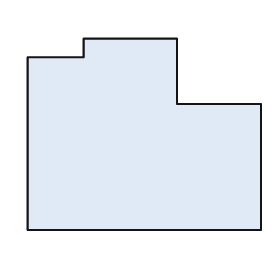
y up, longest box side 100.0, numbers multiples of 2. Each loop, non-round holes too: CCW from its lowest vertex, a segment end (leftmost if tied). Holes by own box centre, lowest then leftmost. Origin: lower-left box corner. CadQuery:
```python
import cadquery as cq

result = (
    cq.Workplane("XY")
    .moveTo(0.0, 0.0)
    .lineTo(100.0, 0.0)
    .lineTo(100.0, 54.0)
    .lineTo(64.0, 54.0)
    .lineTo(64.0, 82.0)
    .lineTo(24.0, 82.0)
    .lineTo(24.0, 74.0)
    .lineTo(0.0, 74.0)
    .close()
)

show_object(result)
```